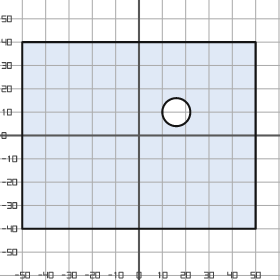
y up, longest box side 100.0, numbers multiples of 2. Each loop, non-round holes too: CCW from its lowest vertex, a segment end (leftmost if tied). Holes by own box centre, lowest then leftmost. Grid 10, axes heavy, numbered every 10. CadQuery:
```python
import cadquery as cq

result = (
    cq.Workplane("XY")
    .moveTo(-50.0, -40.0)
    .lineTo(50.0, -40.0)
    .lineTo(50.0, 40.0)
    .lineTo(-50.0, 40.0)
    .close()
    .moveTo(16.0, 10.0)
    .circle(6.0)
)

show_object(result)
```